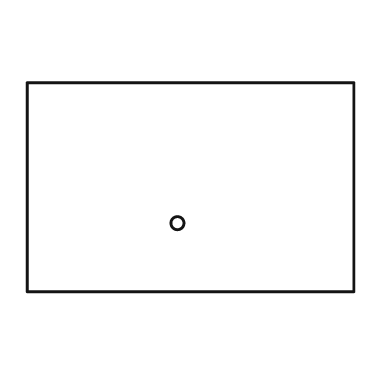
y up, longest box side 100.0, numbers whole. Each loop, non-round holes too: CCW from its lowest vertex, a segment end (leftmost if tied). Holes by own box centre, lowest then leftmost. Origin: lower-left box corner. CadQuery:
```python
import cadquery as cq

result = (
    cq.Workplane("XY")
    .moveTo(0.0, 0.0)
    .lineTo(100.0, 0.0)
    .lineTo(100.0, 64.0)
    .lineTo(0.0, 64.0)
    .close()
    .moveTo(46.0, 21.0)
    .circle(2.0)
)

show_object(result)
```